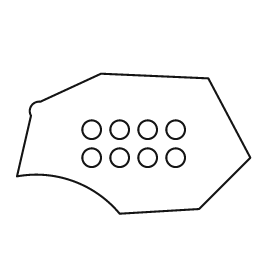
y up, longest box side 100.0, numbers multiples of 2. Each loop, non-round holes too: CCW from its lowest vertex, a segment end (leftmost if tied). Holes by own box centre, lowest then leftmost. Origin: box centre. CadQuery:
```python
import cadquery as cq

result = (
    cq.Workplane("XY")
    .moveTo(-6.0, -30.0)
    .lineTo(28.0, -28.0)
    .lineTo(50.0, -6.0)
    .lineTo(32.0, 28.0)
    .lineTo(-14.0, 30.0)
    .lineTo(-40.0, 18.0)
    .threePointArc((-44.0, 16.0), (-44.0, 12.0))
    .lineTo(-50.0, -14.0)
    .threePointArc((-26.0, -16.0), (-6.0, -30.0))
    .close()
    .moveTo(-18.0, -6.0)
    .circle(4.0)
    .moveTo(-6.0, -6.0)
    .circle(4.0)
    .moveTo(6.0, -6.0)
    .circle(4.0)
    .moveTo(18.0, -6.0)
    .circle(4.0)
    .moveTo(-18.0, 6.0)
    .circle(4.0)
    .moveTo(-6.0, 6.0)
    .circle(4.0)
    .moveTo(6.0, 6.0)
    .circle(4.0)
    .moveTo(18.0, 6.0)
    .circle(4.0)
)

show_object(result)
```